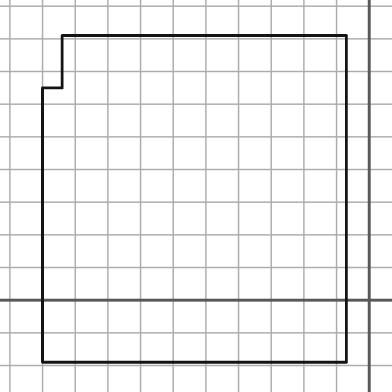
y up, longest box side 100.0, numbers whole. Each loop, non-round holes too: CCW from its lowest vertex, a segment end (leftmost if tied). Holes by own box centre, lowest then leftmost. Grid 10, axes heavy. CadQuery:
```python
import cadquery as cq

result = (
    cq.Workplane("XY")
    .moveTo(-100.0, -19.0)
    .lineTo(-7.0, -19.0)
    .lineTo(-7.0, 81.0)
    .lineTo(-94.0, 81.0)
    .lineTo(-94.0, 65.0)
    .lineTo(-100.0, 65.0)
    .close()
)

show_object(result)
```